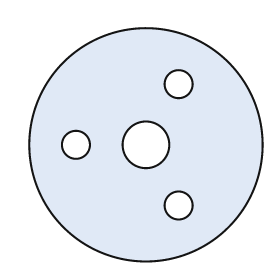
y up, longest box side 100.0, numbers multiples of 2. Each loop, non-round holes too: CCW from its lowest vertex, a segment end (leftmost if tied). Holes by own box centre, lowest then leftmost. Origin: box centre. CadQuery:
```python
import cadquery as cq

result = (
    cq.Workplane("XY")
    .moveTo(0.0, 0.0)
    .circle(50.0)
    .moveTo(14.0, -26.0)
    .circle(6.0)
    .moveTo(-30.0, 0.0)
    .circle(6.0)
    .moveTo(0.0, 0.0)
    .circle(10.0)
    .moveTo(14.0, 26.0)
    .circle(6.0)
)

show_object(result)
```